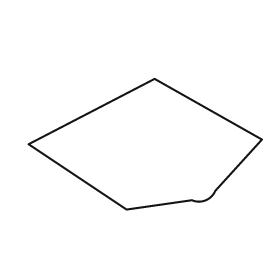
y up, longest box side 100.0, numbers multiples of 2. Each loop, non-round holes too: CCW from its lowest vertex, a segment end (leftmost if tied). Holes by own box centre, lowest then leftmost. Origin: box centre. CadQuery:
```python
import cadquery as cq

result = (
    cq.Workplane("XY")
    .moveTo(-8.0, -28.0)
    .lineTo(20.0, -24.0)
    .threePointArc((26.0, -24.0), (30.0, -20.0))
    .lineTo(50.0, 2.0)
    .lineTo(4.0, 28.0)
    .lineTo(-50.0, 0.0)
    .close()
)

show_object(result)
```